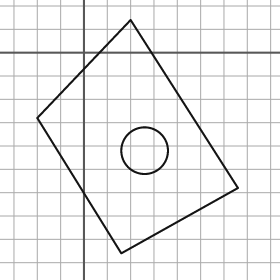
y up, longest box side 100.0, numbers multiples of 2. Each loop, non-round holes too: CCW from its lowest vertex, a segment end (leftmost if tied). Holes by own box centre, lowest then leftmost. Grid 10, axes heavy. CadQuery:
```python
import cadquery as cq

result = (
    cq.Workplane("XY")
    .moveTo(16.0, -86.0)
    .lineTo(66.0, -58.0)
    .lineTo(20.0, 14.0)
    .lineTo(-20.0, -28.0)
    .close()
    .moveTo(26.0, -42.0)
    .circle(10.0)
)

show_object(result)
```